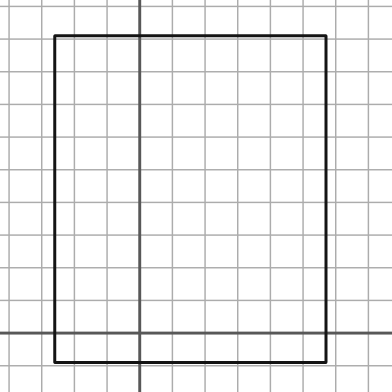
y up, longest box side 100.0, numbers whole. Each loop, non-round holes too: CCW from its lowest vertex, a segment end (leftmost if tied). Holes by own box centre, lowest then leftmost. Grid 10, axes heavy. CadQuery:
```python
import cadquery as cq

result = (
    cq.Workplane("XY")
    .moveTo(-26.0, -9.0)
    .lineTo(57.0, -9.0)
    .lineTo(57.0, 91.0)
    .lineTo(-26.0, 91.0)
    .close()
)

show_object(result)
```